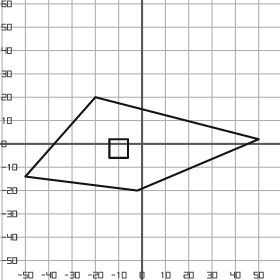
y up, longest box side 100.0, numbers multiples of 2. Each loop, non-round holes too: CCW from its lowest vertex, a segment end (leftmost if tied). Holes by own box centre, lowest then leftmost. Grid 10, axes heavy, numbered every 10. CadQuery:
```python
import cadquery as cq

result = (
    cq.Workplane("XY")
    .moveTo(-2.0, -20.0)
    .lineTo(50.0, 2.0)
    .lineTo(-20.0, 20.0)
    .lineTo(-50.0, -14.0)
    .close()
    .moveTo(-14.0, -6.0)
    .lineTo(-6.0, -6.0)
    .lineTo(-6.0, 2.0)
    .lineTo(-14.0, 2.0)
    .close()
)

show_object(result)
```